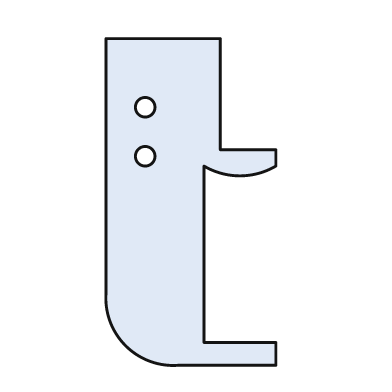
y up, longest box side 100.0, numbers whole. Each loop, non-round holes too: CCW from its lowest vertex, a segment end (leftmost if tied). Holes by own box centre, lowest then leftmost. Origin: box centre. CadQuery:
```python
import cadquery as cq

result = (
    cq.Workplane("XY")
    .moveTo(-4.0, -50.0)
    .lineTo(26.0, -50.0)
    .lineTo(26.0, -43.0)
    .lineTo(4.0, -43.0)
    .lineTo(4.0, 11.0)
    .threePointArc((15.0, 8.0), (26.0, 11.0))
    .lineTo(26.0, 16.0)
    .lineTo(9.0, 16.0)
    .lineTo(9.0, 50.0)
    .lineTo(-26.0, 50.0)
    .lineTo(-26.0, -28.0)
    .threePointArc((-20.0, -44.0), (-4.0, -50.0))
    .close()
    .moveTo(-14.0, 14.0)
    .circle(3.0)
    .moveTo(-14.0, 29.0)
    .circle(3.0)
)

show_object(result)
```